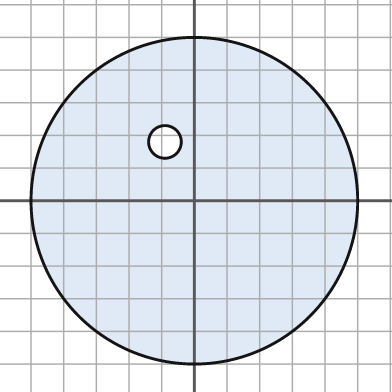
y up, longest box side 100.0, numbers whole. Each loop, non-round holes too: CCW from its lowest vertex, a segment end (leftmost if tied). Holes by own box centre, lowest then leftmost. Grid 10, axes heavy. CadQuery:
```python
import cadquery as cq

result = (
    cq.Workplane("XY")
    .moveTo(0.0, 0.0)
    .circle(50.0)
    .moveTo(-9.0, 18.0)
    .circle(5.0)
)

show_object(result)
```